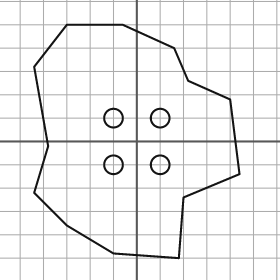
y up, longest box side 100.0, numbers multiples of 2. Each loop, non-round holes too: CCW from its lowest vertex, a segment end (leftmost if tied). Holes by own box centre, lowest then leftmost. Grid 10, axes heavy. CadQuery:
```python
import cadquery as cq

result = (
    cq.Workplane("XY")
    .moveTo(18.0, -50.0)
    .lineTo(20.0, -24.0)
    .lineTo(44.0, -14.0)
    .lineTo(40.0, 18.0)
    .lineTo(22.0, 26.0)
    .lineTo(16.0, 40.0)
    .lineTo(-6.0, 50.0)
    .lineTo(-30.0, 50.0)
    .lineTo(-44.0, 32.0)
    .lineTo(-38.0, -2.0)
    .lineTo(-44.0, -22.0)
    .lineTo(-30.0, -36.0)
    .lineTo(-10.0, -48.0)
    .close()
    .moveTo(-10.0, -10.0)
    .circle(4.0)
    .moveTo(10.0, -10.0)
    .circle(4.0)
    .moveTo(-10.0, 10.0)
    .circle(4.0)
    .moveTo(10.0, 10.0)
    .circle(4.0)
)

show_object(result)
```